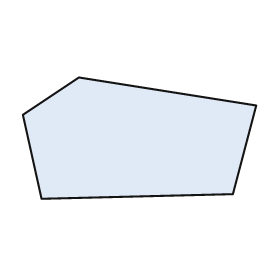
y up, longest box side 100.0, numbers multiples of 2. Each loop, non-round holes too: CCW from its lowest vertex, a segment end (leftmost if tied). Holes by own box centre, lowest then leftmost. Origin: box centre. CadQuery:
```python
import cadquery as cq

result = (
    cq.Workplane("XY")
    .moveTo(-42.0, -26.0)
    .lineTo(40.0, -24.0)
    .lineTo(50.0, 14.0)
    .lineTo(-26.0, 26.0)
    .lineTo(-50.0, 10.0)
    .close()
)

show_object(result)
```